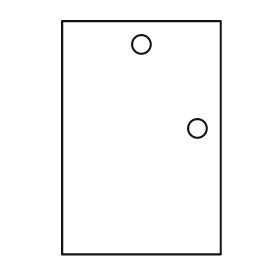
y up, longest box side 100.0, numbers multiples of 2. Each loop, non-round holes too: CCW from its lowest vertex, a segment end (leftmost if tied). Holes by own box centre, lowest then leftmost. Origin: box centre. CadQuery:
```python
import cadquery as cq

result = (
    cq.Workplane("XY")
    .moveTo(-34.0, -50.0)
    .lineTo(34.0, -50.0)
    .lineTo(34.0, 50.0)
    .lineTo(-34.0, 50.0)
    .close()
    .moveTo(24.0, 4.0)
    .circle(4.0)
    .moveTo(0.0, 40.0)
    .circle(4.0)
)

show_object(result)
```